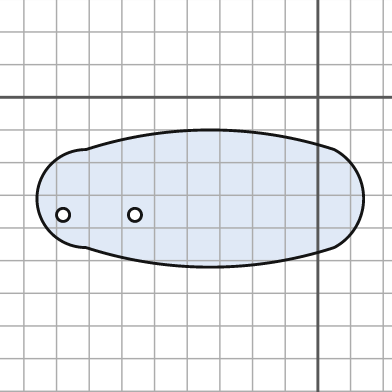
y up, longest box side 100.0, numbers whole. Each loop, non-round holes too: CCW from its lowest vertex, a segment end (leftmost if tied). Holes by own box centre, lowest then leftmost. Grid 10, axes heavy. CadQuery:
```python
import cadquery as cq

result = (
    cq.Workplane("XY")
    .moveTo(-71.0, -46.0)
    .threePointArc((-33.0, -52.0), (5.0, -46.0))
    .threePointArc((14.0, -31.0), (5.0, -16.0))
    .threePointArc((-33.0, -10.0), (-71.0, -16.0))
    .threePointArc((-86.0, -31.0), (-71.0, -46.0))
    .close()
    .moveTo(-78.0, -36.0)
    .circle(2.0)
    .moveTo(-56.0, -36.0)
    .circle(2.0)
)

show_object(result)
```